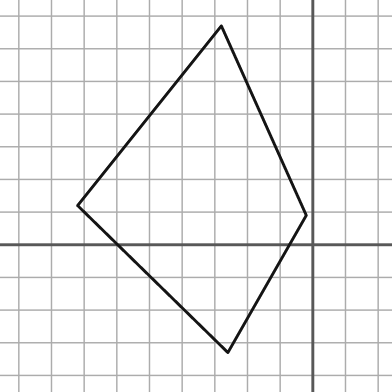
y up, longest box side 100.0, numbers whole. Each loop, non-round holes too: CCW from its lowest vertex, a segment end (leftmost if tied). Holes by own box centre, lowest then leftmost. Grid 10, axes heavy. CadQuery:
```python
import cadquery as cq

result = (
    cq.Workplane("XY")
    .moveTo(-26.0, -33.0)
    .lineTo(-2.0, 9.0)
    .lineTo(-28.0, 67.0)
    .lineTo(-72.0, 12.0)
    .close()
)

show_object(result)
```